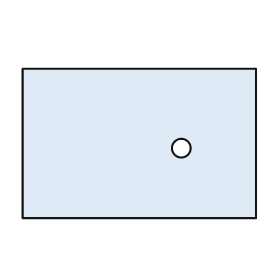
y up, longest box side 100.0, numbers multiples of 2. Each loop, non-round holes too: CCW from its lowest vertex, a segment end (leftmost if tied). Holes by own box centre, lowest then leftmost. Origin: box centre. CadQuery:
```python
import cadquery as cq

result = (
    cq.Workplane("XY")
    .moveTo(-50.0, -32.0)
    .lineTo(50.0, -32.0)
    .lineTo(50.0, 32.0)
    .lineTo(-50.0, 32.0)
    .close()
    .moveTo(18.0, -2.0)
    .circle(4.0)
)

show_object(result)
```